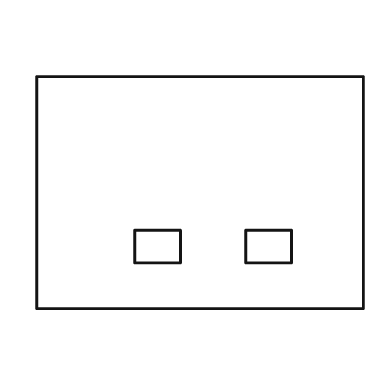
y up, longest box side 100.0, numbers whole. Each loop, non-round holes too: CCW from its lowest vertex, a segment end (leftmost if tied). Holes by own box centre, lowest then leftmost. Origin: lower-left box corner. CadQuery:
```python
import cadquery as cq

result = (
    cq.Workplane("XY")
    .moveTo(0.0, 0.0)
    .lineTo(100.0, 0.0)
    .lineTo(100.0, 71.0)
    .lineTo(0.0, 71.0)
    .close()
    .moveTo(30.0, 14.0)
    .lineTo(44.0, 14.0)
    .lineTo(44.0, 24.0)
    .lineTo(30.0, 24.0)
    .close()
    .moveTo(64.0, 14.0)
    .lineTo(78.0, 14.0)
    .lineTo(78.0, 24.0)
    .lineTo(64.0, 24.0)
    .close()
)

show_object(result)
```